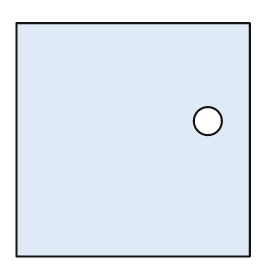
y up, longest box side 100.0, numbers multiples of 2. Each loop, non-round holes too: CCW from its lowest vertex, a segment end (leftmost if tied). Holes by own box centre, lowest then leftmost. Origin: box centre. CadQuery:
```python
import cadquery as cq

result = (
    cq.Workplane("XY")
    .moveTo(-50.0, -50.0)
    .lineTo(50.0, -50.0)
    .lineTo(50.0, 50.0)
    .lineTo(-50.0, 50.0)
    .close()
    .moveTo(32.0, 8.0)
    .circle(6.0)
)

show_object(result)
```